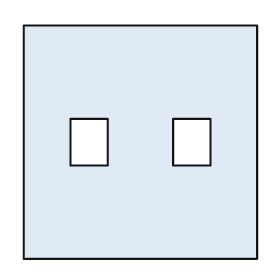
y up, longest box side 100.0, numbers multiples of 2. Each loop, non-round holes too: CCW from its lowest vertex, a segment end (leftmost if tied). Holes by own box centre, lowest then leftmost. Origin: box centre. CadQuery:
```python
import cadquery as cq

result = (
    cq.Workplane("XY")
    .moveTo(-50.0, -50.0)
    .lineTo(50.0, -50.0)
    .lineTo(50.0, 50.0)
    .lineTo(-50.0, 50.0)
    .close()
    .moveTo(-30.0, -10.0)
    .lineTo(-14.0, -10.0)
    .lineTo(-14.0, 10.0)
    .lineTo(-30.0, 10.0)
    .close()
    .moveTo(14.0, -10.0)
    .lineTo(30.0, -10.0)
    .lineTo(30.0, 10.0)
    .lineTo(14.0, 10.0)
    .close()
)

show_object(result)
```